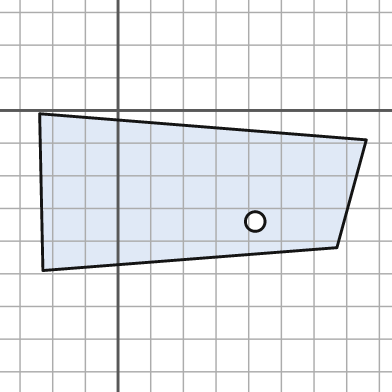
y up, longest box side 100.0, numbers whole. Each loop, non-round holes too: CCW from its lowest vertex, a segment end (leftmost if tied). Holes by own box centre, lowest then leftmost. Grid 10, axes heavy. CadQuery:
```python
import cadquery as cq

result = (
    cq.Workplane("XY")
    .moveTo(-23.0, -49.0)
    .lineTo(67.0, -42.0)
    .lineTo(76.0, -9.0)
    .lineTo(-24.0, -1.0)
    .close()
    .moveTo(42.0, -34.0)
    .circle(3.0)
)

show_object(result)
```